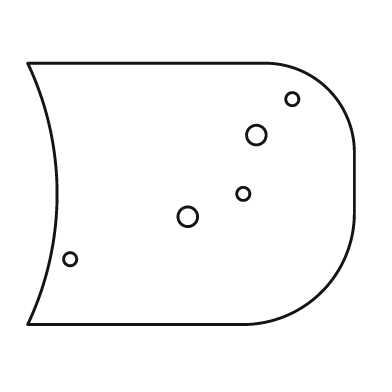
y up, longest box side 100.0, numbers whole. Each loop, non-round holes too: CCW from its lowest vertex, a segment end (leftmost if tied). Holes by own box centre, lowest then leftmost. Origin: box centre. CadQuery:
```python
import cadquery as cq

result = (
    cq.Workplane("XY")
    .moveTo(-50.0, -40.0)
    .lineTo(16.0, -40.0)
    .threePointArc((40.0, -30.0), (50.0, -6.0))
    .lineTo(50.0, 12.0)
    .threePointArc((42.0, 32.0), (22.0, 40.0))
    .lineTo(-50.0, 40.0)
    .threePointArc((-41.0, 0.0), (-50.0, -40.0))
    .close()
    .moveTo(-37.0, -20.0)
    .circle(2.0)
    .moveTo(-1.0, -7.0)
    .circle(3.0)
    .moveTo(16.0, 0.0)
    .circle(2.0)
    .moveTo(20.0, 18.0)
    .circle(3.0)
    .moveTo(31.0, 29.0)
    .circle(2.0)
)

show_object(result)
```